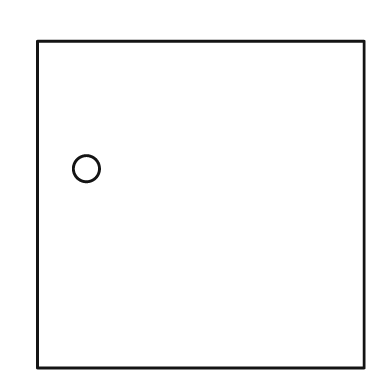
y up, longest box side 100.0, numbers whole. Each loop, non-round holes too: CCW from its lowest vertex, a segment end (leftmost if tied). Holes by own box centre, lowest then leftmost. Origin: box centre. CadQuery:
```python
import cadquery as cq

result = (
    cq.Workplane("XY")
    .moveTo(-50.0, -50.0)
    .lineTo(50.0, -50.0)
    .lineTo(50.0, 50.0)
    .lineTo(-50.0, 50.0)
    .close()
    .moveTo(-35.0, 11.0)
    .circle(4.0)
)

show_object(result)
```